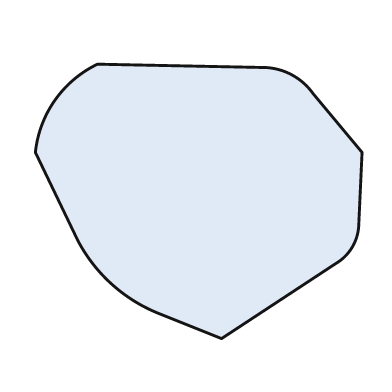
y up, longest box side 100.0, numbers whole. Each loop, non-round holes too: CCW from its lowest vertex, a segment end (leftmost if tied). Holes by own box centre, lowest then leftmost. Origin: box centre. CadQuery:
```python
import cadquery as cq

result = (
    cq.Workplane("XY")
    .moveTo(7.0, -42.0)
    .lineTo(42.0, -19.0)
    .threePointArc((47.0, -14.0), (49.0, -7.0))
    .lineTo(50.0, 15.0)
    .lineTo(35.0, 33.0)
    .threePointArc((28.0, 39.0), (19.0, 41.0))
    .lineTo(-31.0, 42.0)
    .threePointArc((-44.0, 31.0), (-50.0, 15.0))
    .lineTo(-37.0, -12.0)
    .threePointArc((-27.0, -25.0), (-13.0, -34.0))
    .close()
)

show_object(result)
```